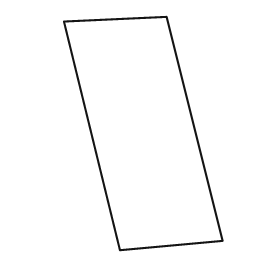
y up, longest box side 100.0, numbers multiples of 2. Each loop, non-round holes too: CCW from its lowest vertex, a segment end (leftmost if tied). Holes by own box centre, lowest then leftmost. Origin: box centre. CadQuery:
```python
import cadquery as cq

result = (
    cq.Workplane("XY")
    .moveTo(-10.0, -50.0)
    .lineTo(34.0, -46.0)
    .lineTo(10.0, 50.0)
    .lineTo(-34.0, 48.0)
    .close()
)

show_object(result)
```